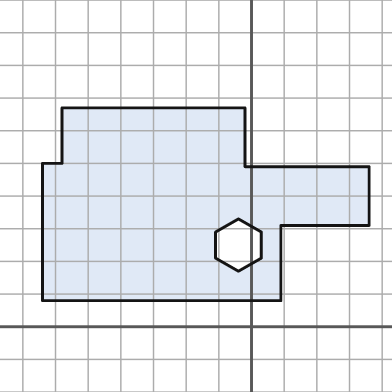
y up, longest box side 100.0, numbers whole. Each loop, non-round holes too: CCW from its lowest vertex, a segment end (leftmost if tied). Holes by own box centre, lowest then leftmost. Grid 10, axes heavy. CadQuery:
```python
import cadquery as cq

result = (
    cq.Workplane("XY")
    .moveTo(-64.0, 8.0)
    .lineTo(9.0, 8.0)
    .lineTo(9.0, 31.0)
    .lineTo(36.0, 31.0)
    .lineTo(36.0, 49.0)
    .lineTo(-2.0, 49.0)
    .lineTo(-2.0, 67.0)
    .lineTo(-58.0, 67.0)
    .lineTo(-58.0, 50.0)
    .lineTo(-64.0, 50.0)
    .close()
    .moveTo(-4.0, 17.0)
    .lineTo(3.0, 21.0)
    .lineTo(3.0, 29.0)
    .lineTo(-4.0, 33.0)
    .lineTo(-11.0, 29.0)
    .lineTo(-11.0, 21.0)
    .close()
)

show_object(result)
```